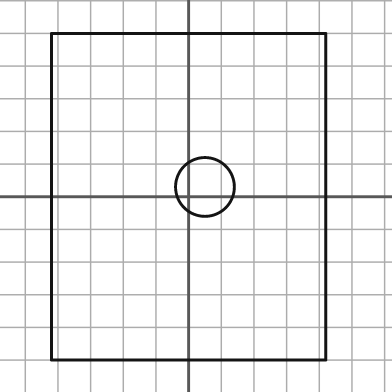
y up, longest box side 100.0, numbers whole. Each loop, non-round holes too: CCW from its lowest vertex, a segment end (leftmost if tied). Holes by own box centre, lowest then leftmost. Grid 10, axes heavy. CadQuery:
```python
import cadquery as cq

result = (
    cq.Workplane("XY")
    .moveTo(-42.0, -50.0)
    .lineTo(42.0, -50.0)
    .lineTo(42.0, 50.0)
    .lineTo(-42.0, 50.0)
    .close()
    .moveTo(5.0, 3.0)
    .circle(9.0)
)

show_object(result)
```